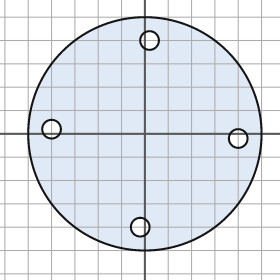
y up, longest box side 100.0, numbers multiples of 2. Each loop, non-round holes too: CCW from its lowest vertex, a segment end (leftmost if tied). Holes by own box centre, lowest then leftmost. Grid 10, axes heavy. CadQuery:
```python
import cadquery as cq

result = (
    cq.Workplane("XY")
    .moveTo(0.0, 0.0)
    .circle(50.0)
    .moveTo(-2.0, -40.0)
    .circle(4.0)
    .moveTo(40.0, -2.0)
    .circle(4.0)
    .moveTo(-40.0, 2.0)
    .circle(4.0)
    .moveTo(2.0, 40.0)
    .circle(4.0)
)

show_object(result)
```